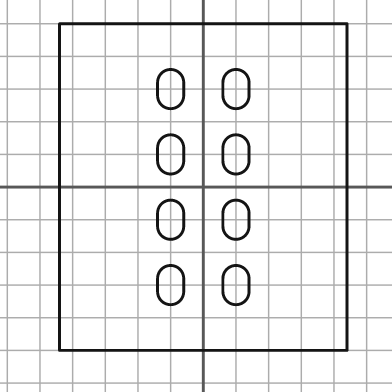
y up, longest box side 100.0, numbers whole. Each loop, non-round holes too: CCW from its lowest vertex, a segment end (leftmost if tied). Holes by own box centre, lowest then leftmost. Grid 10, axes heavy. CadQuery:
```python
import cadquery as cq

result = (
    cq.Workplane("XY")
    .moveTo(-44.0, -50.0)
    .lineTo(44.0, -50.0)
    .lineTo(44.0, 50.0)
    .lineTo(-44.0, 50.0)
    .close()
    .moveTo(-14.0, -32.0)
    .threePointArc((-10.0, -36.0), (-6.0, -32.0))
    .lineTo(-6.0, -28.0)
    .threePointArc((-10.0, -24.0), (-14.0, -28.0))
    .close()
    .moveTo(6.0, -32.0)
    .threePointArc((10.0, -36.0), (14.0, -32.0))
    .lineTo(14.0, -28.0)
    .threePointArc((10.0, -24.0), (6.0, -28.0))
    .close()
    .moveTo(-14.0, -12.0)
    .threePointArc((-10.0, -16.0), (-6.0, -12.0))
    .lineTo(-6.0, -8.0)
    .threePointArc((-10.0, -4.0), (-14.0, -8.0))
    .close()
    .moveTo(6.0, -12.0)
    .threePointArc((10.0, -16.0), (14.0, -12.0))
    .lineTo(14.0, -8.0)
    .threePointArc((10.0, -4.0), (6.0, -8.0))
    .close()
    .moveTo(-14.0, 8.0)
    .threePointArc((-10.0, 4.0), (-6.0, 8.0))
    .lineTo(-6.0, 12.0)
    .threePointArc((-10.0, 16.0), (-14.0, 12.0))
    .close()
    .moveTo(6.0, 8.0)
    .threePointArc((10.0, 4.0), (14.0, 8.0))
    .lineTo(14.0, 12.0)
    .threePointArc((10.0, 16.0), (6.0, 12.0))
    .close()
    .moveTo(-14.0, 28.0)
    .threePointArc((-10.0, 24.0), (-6.0, 28.0))
    .lineTo(-6.0, 32.0)
    .threePointArc((-10.0, 36.0), (-14.0, 32.0))
    .close()
    .moveTo(6.0, 28.0)
    .threePointArc((10.0, 24.0), (14.0, 28.0))
    .lineTo(14.0, 32.0)
    .threePointArc((10.0, 36.0), (6.0, 32.0))
    .close()
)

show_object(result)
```